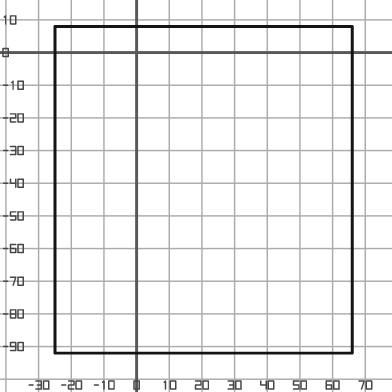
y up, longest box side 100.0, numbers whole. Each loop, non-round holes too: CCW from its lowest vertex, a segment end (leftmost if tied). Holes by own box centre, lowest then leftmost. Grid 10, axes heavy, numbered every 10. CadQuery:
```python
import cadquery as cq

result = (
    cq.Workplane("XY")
    .moveTo(-25.0, -92.0)
    .lineTo(66.0, -92.0)
    .lineTo(66.0, 8.0)
    .lineTo(-25.0, 8.0)
    .close()
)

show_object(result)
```